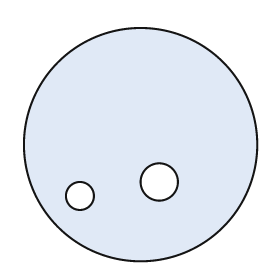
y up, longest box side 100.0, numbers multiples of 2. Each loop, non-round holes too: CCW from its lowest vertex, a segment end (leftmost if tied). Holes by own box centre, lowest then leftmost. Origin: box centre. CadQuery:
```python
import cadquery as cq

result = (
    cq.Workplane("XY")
    .moveTo(0.0, 0.0)
    .circle(50.0)
    .moveTo(-26.0, -22.0)
    .circle(6.0)
    .moveTo(8.0, -16.0)
    .circle(8.0)
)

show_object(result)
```